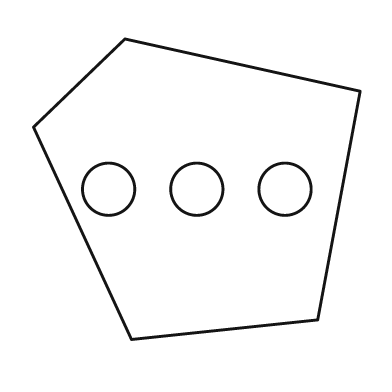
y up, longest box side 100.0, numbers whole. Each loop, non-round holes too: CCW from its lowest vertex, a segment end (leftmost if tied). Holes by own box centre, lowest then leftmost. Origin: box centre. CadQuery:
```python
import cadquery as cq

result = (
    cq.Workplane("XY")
    .moveTo(-20.0, -46.0)
    .lineTo(37.0, -40.0)
    .lineTo(50.0, 30.0)
    .lineTo(-22.0, 46.0)
    .lineTo(-50.0, 19.0)
    .close()
    .moveTo(-27.0, 0.0)
    .circle(8.0)
    .moveTo(0.0, 0.0)
    .circle(8.0)
    .moveTo(27.0, 0.0)
    .circle(8.0)
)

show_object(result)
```